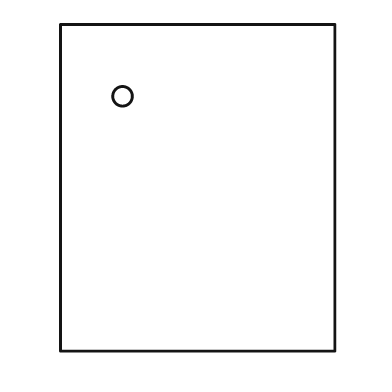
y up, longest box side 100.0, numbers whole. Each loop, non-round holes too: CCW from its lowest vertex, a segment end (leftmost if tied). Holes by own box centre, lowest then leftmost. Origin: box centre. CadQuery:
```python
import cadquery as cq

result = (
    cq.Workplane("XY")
    .moveTo(-42.0, -50.0)
    .lineTo(42.0, -50.0)
    .lineTo(42.0, 50.0)
    .lineTo(-42.0, 50.0)
    .close()
    .moveTo(-23.0, 28.0)
    .circle(3.0)
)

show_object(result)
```